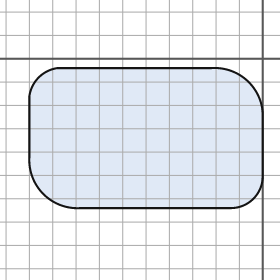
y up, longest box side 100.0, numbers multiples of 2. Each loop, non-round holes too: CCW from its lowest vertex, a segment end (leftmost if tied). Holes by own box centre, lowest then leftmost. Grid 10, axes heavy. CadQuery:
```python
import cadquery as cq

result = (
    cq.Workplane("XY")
    .moveTo(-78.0, -64.0)
    .lineTo(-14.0, -64.0)
    .threePointArc((-4.0, -60.0), (0.0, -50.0))
    .lineTo(0.0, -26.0)
    .threePointArc((-6.0, -10.0), (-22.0, -4.0))
    .lineTo(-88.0, -4.0)
    .threePointArc((-96.0, -8.0), (-100.0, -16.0))
    .lineTo(-100.0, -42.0)
    .threePointArc((-94.0, -58.0), (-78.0, -64.0))
    .close()
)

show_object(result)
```